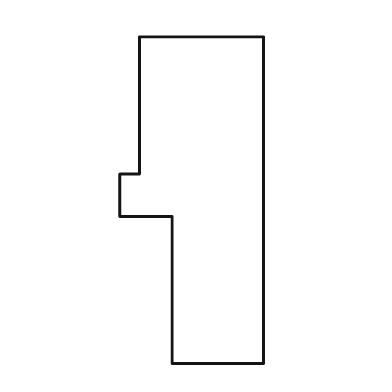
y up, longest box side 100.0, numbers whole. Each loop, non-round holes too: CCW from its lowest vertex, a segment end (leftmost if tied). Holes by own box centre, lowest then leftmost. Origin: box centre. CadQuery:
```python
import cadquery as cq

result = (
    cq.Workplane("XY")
    .moveTo(-6.0, -50.0)
    .lineTo(22.0, -50.0)
    .lineTo(22.0, 50.0)
    .lineTo(-16.0, 50.0)
    .lineTo(-16.0, 8.0)
    .lineTo(-22.0, 8.0)
    .lineTo(-22.0, -5.0)
    .lineTo(-6.0, -5.0)
    .close()
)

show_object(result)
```